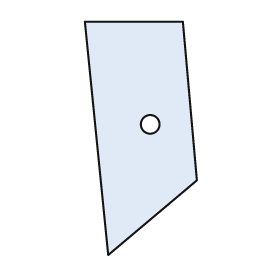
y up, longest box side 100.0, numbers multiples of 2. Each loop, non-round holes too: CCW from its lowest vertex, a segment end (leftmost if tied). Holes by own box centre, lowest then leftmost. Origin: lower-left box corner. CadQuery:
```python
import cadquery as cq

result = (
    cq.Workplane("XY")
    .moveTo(10.0, 0.0)
    .lineTo(48.0, 32.0)
    .lineTo(42.0, 100.0)
    .lineTo(0.0, 100.0)
    .close()
    .moveTo(28.0, 56.0)
    .circle(4.0)
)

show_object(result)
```